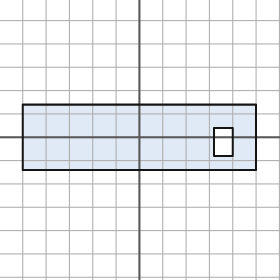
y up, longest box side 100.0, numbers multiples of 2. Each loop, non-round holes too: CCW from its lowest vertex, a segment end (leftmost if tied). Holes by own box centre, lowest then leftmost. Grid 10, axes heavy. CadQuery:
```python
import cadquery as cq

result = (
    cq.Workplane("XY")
    .moveTo(-50.0, -14.0)
    .lineTo(50.0, -14.0)
    .lineTo(50.0, 14.0)
    .lineTo(-50.0, 14.0)
    .close()
    .moveTo(32.0, -8.0)
    .lineTo(40.0, -8.0)
    .lineTo(40.0, 4.0)
    .lineTo(32.0, 4.0)
    .close()
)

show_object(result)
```